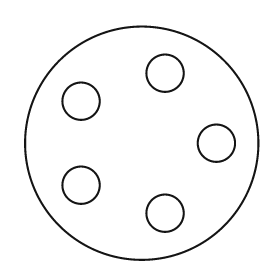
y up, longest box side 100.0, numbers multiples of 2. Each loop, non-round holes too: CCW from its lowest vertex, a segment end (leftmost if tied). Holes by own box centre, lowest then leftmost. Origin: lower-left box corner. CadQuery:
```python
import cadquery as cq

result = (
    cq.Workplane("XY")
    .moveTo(50.0, 50.0)
    .circle(50.0)
    .moveTo(60.0, 20.0)
    .circle(8.0)
    .moveTo(24.0, 32.0)
    .circle(8.0)
    .moveTo(82.0, 50.0)
    .circle(8.0)
    .moveTo(24.0, 68.0)
    .circle(8.0)
    .moveTo(60.0, 80.0)
    .circle(8.0)
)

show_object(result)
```